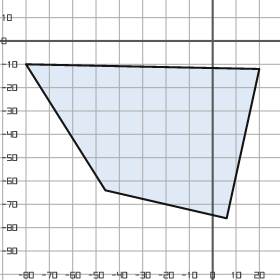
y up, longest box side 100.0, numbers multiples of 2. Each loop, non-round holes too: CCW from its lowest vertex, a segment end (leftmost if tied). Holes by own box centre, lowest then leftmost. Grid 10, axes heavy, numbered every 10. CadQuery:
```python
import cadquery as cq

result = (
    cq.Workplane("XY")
    .moveTo(6.0, -76.0)
    .lineTo(20.0, -12.0)
    .lineTo(-80.0, -10.0)
    .lineTo(-46.0, -64.0)
    .close()
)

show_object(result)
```